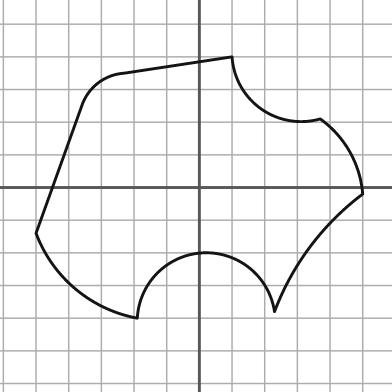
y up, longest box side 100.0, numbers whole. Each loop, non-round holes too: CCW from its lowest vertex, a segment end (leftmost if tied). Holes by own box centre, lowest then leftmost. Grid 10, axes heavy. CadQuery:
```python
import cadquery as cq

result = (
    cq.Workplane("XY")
    .moveTo(-19.0, -40.0)
    .threePointArc((1.0, -20.0), (23.0, -38.0))
    .threePointArc((34.0, -18.0), (50.0, -2.0))
    .threePointArc((46.0, 11.0), (37.0, 21.0))
    .threePointArc((19.0, 24.0), (10.0, 40.0))
    .lineTo(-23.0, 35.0)
    .threePointArc((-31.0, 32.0), (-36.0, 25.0))
    .lineTo(-50.0, -14.0)
    .threePointArc((-38.0, -31.0), (-19.0, -40.0))
    .close()
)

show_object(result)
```